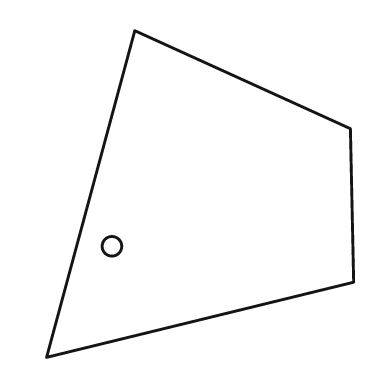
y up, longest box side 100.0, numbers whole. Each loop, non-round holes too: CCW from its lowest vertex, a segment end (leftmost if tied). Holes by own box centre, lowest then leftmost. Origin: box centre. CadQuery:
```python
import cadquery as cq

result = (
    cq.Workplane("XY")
    .moveTo(-47.0, -50.0)
    .lineTo(47.0, -27.0)
    .lineTo(46.0, 20.0)
    .lineTo(-20.0, 50.0)
    .close()
    .moveTo(-27.0, -16.0)
    .circle(3.0)
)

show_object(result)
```